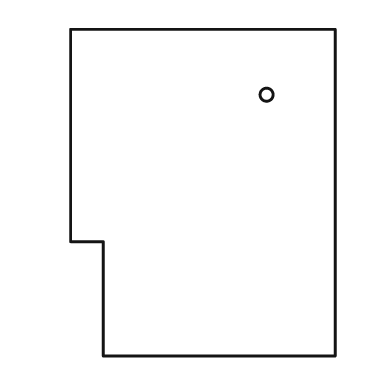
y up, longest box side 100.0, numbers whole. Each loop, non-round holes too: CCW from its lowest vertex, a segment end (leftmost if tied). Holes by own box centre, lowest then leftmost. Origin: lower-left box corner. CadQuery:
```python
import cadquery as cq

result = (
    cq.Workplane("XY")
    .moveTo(10.0, 0.0)
    .lineTo(81.0, 0.0)
    .lineTo(81.0, 100.0)
    .lineTo(0.0, 100.0)
    .lineTo(0.0, 35.0)
    .lineTo(10.0, 35.0)
    .close()
    .moveTo(60.0, 80.0)
    .circle(2.0)
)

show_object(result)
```